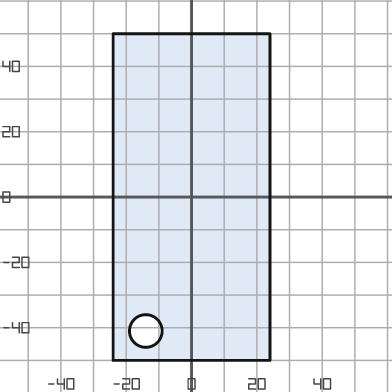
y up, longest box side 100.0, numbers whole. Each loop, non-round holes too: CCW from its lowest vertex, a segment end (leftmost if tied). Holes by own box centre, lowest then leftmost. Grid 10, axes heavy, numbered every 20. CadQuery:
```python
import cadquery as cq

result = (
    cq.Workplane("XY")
    .moveTo(-24.0, -50.0)
    .lineTo(24.0, -50.0)
    .lineTo(24.0, 50.0)
    .lineTo(-24.0, 50.0)
    .close()
    .moveTo(-14.0, -41.0)
    .circle(5.0)
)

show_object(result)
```